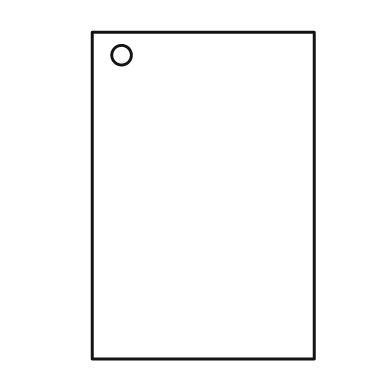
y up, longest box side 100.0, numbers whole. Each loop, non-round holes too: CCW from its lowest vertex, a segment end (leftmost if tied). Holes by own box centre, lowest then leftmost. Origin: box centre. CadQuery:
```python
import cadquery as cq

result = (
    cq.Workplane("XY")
    .moveTo(-34.0, -50.0)
    .lineTo(34.0, -50.0)
    .lineTo(34.0, 50.0)
    .lineTo(-34.0, 50.0)
    .close()
    .moveTo(-25.0, 43.0)
    .circle(3.0)
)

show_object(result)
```